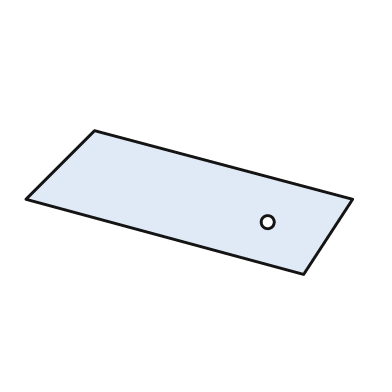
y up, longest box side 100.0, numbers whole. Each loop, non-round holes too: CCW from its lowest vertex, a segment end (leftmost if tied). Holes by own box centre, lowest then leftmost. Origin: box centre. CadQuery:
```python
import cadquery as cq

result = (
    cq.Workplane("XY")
    .moveTo(35.0, -22.0)
    .lineTo(50.0, 1.0)
    .lineTo(-29.0, 22.0)
    .lineTo(-50.0, 1.0)
    .close()
    .moveTo(24.0, -6.0)
    .circle(2.0)
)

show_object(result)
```